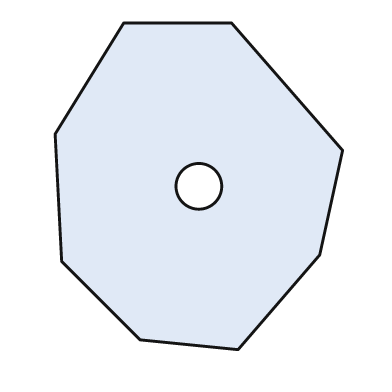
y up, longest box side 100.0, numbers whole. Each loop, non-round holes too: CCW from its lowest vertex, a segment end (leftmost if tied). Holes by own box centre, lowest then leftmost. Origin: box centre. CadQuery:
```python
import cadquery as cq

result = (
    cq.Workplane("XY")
    .moveTo(12.0, -50.0)
    .lineTo(37.0, -21.0)
    .lineTo(44.0, 11.0)
    .lineTo(10.0, 50.0)
    .lineTo(-23.0, 50.0)
    .lineTo(-44.0, 16.0)
    .lineTo(-42.0, -23.0)
    .lineTo(-18.0, -47.0)
    .close()
    .moveTo(0.0, 0.0)
    .circle(7.0)
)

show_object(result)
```